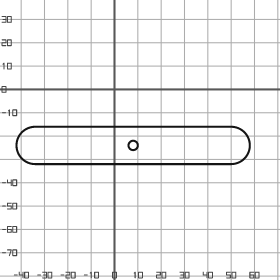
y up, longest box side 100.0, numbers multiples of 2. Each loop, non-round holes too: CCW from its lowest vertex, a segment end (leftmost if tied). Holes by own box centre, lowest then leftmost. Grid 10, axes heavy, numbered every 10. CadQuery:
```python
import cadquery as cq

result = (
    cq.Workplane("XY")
    .moveTo(-34.0, -32.0)
    .lineTo(50.0, -32.0)
    .threePointArc((58.0, -24.0), (50.0, -16.0))
    .lineTo(-34.0, -16.0)
    .threePointArc((-42.0, -24.0), (-34.0, -32.0))
    .close()
    .moveTo(8.0, -24.0)
    .circle(2.0)
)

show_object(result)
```